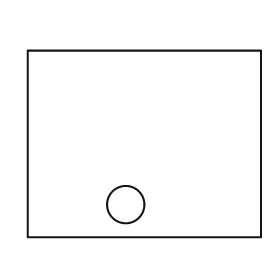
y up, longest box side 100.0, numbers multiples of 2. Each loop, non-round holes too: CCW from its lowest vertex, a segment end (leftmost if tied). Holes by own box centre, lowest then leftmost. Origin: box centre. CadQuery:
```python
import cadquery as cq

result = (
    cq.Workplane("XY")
    .moveTo(-50.0, -40.0)
    .lineTo(50.0, -40.0)
    .lineTo(50.0, 40.0)
    .lineTo(-50.0, 40.0)
    .close()
    .moveTo(-8.0, -26.0)
    .circle(8.0)
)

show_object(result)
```